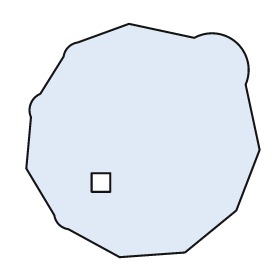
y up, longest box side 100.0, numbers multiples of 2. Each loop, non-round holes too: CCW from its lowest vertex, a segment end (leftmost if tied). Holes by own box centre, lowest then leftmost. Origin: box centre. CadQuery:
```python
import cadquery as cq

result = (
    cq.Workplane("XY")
    .moveTo(-10.0, -50.0)
    .lineTo(18.0, -48.0)
    .lineTo(40.0, -30.0)
    .lineTo(50.0, -4.0)
    .lineTo(44.0, 24.0)
    .threePointArc((40.0, 42.0), (22.0, 44.0))
    .lineTo(-6.0, 50.0)
    .lineTo(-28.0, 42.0)
    .threePointArc((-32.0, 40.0), (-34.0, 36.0))
    .lineTo(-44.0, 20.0)
    .threePointArc((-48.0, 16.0), (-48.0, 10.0))
    .lineTo(-50.0, -12.0)
    .lineTo(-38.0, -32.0)
    .threePointArc((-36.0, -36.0), (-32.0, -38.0))
    .close()
    .moveTo(-22.0, -22.0)
    .lineTo(-14.0, -22.0)
    .lineTo(-14.0, -14.0)
    .lineTo(-22.0, -14.0)
    .close()
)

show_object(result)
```